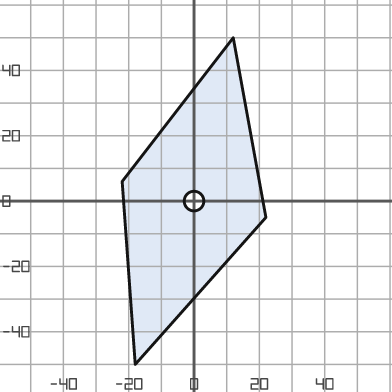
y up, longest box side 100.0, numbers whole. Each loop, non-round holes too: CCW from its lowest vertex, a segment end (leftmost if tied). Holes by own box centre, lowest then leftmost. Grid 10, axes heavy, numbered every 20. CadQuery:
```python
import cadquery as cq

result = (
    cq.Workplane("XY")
    .moveTo(-18.0, -50.0)
    .lineTo(22.0, -5.0)
    .lineTo(12.0, 50.0)
    .lineTo(-22.0, 6.0)
    .close()
    .moveTo(0.0, 0.0)
    .circle(3.0)
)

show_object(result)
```